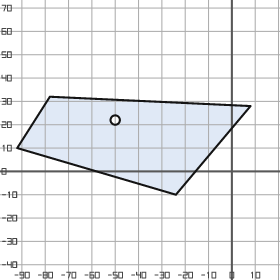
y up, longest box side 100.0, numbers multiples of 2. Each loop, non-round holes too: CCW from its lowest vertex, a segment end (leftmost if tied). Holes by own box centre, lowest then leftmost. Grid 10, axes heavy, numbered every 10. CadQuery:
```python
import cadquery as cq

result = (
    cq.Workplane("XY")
    .moveTo(-24.0, -10.0)
    .lineTo(8.0, 28.0)
    .lineTo(-78.0, 32.0)
    .lineTo(-92.0, 10.0)
    .close()
    .moveTo(-50.0, 22.0)
    .circle(2.0)
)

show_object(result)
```